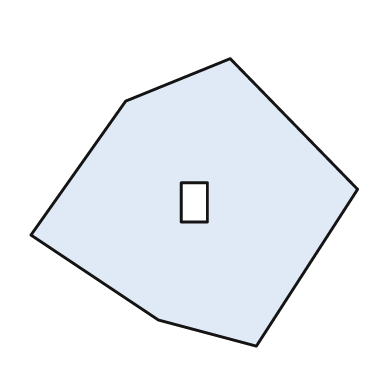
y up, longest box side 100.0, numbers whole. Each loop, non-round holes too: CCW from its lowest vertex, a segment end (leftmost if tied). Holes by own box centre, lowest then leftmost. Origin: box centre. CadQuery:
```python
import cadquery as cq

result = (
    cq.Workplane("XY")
    .moveTo(19.0, -44.0)
    .lineTo(50.0, 4.0)
    .lineTo(11.0, 44.0)
    .lineTo(-21.0, 31.0)
    .lineTo(-50.0, -10.0)
    .lineTo(-11.0, -36.0)
    .close()
    .moveTo(-4.0, -6.0)
    .lineTo(4.0, -6.0)
    .lineTo(4.0, 6.0)
    .lineTo(-4.0, 6.0)
    .close()
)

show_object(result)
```